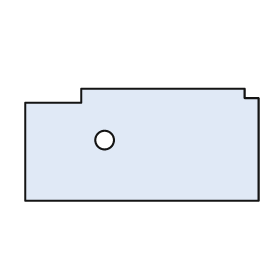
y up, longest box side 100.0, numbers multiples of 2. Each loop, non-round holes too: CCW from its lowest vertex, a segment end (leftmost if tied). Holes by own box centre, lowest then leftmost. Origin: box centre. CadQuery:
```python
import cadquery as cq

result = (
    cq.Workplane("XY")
    .moveTo(-50.0, -24.0)
    .lineTo(50.0, -24.0)
    .lineTo(50.0, 20.0)
    .lineTo(44.0, 20.0)
    .lineTo(44.0, 24.0)
    .lineTo(-26.0, 24.0)
    .lineTo(-26.0, 18.0)
    .lineTo(-50.0, 18.0)
    .close()
    .moveTo(-16.0, 2.0)
    .circle(4.0)
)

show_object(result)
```